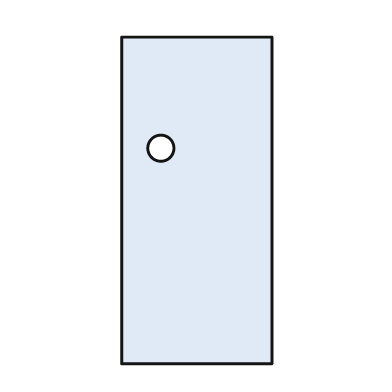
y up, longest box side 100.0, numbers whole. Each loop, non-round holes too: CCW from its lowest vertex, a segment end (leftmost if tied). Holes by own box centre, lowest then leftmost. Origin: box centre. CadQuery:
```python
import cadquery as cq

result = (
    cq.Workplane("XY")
    .moveTo(-23.0, -50.0)
    .lineTo(23.0, -50.0)
    .lineTo(23.0, 50.0)
    .lineTo(-23.0, 50.0)
    .close()
    .moveTo(-11.0, 16.0)
    .circle(4.0)
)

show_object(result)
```